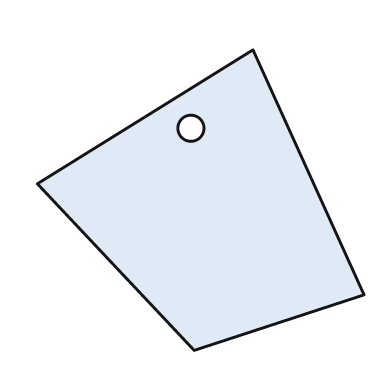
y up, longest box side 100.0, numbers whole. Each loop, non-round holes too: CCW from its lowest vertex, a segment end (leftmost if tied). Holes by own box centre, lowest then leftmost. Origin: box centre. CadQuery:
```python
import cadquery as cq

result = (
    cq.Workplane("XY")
    .moveTo(-2.0, -46.0)
    .lineTo(50.0, -29.0)
    .lineTo(16.0, 46.0)
    .lineTo(-50.0, 5.0)
    .close()
    .moveTo(-3.0, 22.0)
    .circle(4.0)
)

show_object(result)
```